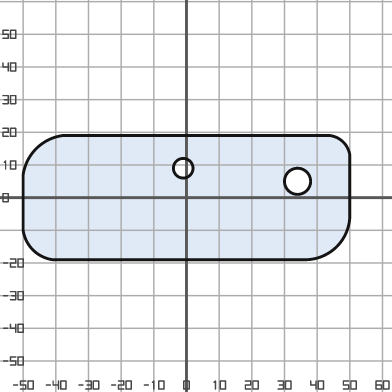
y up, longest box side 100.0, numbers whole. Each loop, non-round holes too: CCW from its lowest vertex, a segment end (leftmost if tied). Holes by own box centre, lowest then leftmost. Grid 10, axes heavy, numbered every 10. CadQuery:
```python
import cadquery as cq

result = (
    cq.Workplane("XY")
    .moveTo(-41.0, -19.0)
    .lineTo(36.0, -19.0)
    .threePointArc((46.0, -15.0), (50.0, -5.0))
    .lineTo(50.0, 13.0)
    .threePointArc((48.0, 17.0), (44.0, 19.0))
    .lineTo(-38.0, 19.0)
    .threePointArc((-46.0, 15.0), (-50.0, 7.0))
    .lineTo(-50.0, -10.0)
    .threePointArc((-47.0, -16.0), (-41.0, -19.0))
    .close()
    .moveTo(34.0, 5.0)
    .circle(4.0)
    .moveTo(-1.0, 9.0)
    .circle(3.0)
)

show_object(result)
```